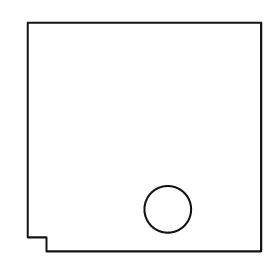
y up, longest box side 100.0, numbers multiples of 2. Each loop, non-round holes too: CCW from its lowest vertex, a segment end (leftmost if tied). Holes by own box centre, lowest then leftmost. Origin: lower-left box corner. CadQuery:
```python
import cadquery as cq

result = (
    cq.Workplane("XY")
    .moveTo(8.0, 0.0)
    .lineTo(100.0, 0.0)
    .lineTo(100.0, 98.0)
    .lineTo(0.0, 98.0)
    .lineTo(0.0, 6.0)
    .lineTo(8.0, 6.0)
    .close()
    .moveTo(60.0, 18.0)
    .circle(10.0)
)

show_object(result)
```